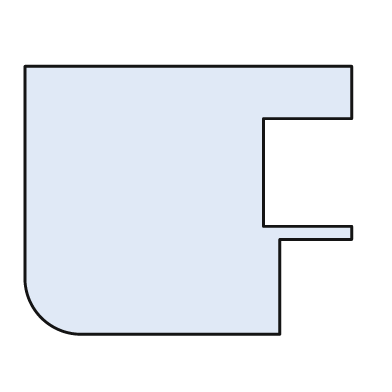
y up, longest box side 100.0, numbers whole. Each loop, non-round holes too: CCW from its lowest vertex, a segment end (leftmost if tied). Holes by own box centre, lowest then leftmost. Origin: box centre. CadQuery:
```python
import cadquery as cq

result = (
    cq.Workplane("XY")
    .moveTo(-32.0, -41.0)
    .lineTo(28.0, -41.0)
    .lineTo(28.0, -12.0)
    .lineTo(50.0, -12.0)
    .lineTo(50.0, -8.0)
    .lineTo(23.0, -8.0)
    .lineTo(23.0, 25.0)
    .lineTo(50.0, 25.0)
    .lineTo(50.0, 41.0)
    .lineTo(-50.0, 41.0)
    .lineTo(-50.0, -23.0)
    .threePointArc((-45.0, -36.0), (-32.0, -41.0))
    .close()
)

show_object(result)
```